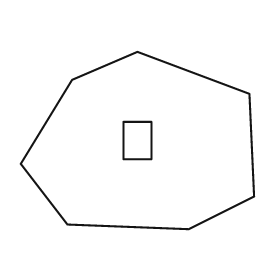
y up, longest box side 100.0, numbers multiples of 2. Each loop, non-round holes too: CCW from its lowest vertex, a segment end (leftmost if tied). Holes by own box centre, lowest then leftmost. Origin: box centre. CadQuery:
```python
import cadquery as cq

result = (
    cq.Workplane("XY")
    .moveTo(22.0, -38.0)
    .lineTo(50.0, -24.0)
    .lineTo(48.0, 20.0)
    .lineTo(0.0, 38.0)
    .lineTo(-28.0, 26.0)
    .lineTo(-50.0, -10.0)
    .lineTo(-30.0, -36.0)
    .close()
    .moveTo(-6.0, -8.0)
    .lineTo(6.0, -8.0)
    .lineTo(6.0, 8.0)
    .lineTo(-6.0, 8.0)
    .close()
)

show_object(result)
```